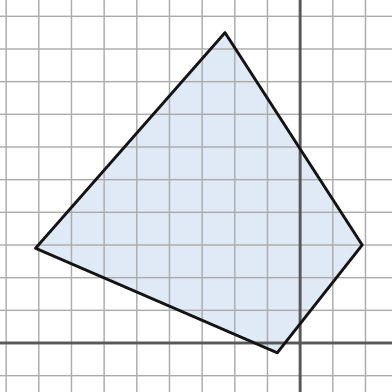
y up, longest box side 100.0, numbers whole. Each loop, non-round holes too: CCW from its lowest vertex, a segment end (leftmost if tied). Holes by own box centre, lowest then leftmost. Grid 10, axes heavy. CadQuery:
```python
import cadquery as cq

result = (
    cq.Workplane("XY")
    .moveTo(-7.0, -3.0)
    .lineTo(19.0, 30.0)
    .lineTo(-23.0, 95.0)
    .lineTo(-81.0, 29.0)
    .close()
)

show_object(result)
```